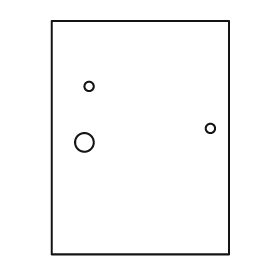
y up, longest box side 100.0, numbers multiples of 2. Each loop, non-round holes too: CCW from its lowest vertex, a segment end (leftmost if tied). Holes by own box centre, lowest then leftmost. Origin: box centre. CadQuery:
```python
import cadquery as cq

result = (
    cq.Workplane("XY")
    .moveTo(-38.0, -50.0)
    .lineTo(38.0, -50.0)
    .lineTo(38.0, 50.0)
    .lineTo(-38.0, 50.0)
    .close()
    .moveTo(-24.0, -2.0)
    .circle(4.0)
    .moveTo(30.0, 4.0)
    .circle(2.0)
    .moveTo(-22.0, 22.0)
    .circle(2.0)
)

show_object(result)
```